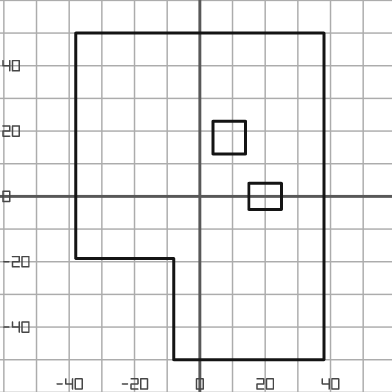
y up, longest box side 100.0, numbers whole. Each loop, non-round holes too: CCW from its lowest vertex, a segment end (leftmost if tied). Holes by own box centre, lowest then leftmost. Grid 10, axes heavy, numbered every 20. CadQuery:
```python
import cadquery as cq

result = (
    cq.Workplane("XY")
    .moveTo(-8.0, -50.0)
    .lineTo(38.0, -50.0)
    .lineTo(38.0, 50.0)
    .lineTo(-38.0, 50.0)
    .lineTo(-38.0, -19.0)
    .lineTo(-8.0, -19.0)
    .close()
    .moveTo(15.0, -4.0)
    .lineTo(25.0, -4.0)
    .lineTo(25.0, 4.0)
    .lineTo(15.0, 4.0)
    .close()
    .moveTo(4.0, 13.0)
    .lineTo(14.0, 13.0)
    .lineTo(14.0, 23.0)
    .lineTo(4.0, 23.0)
    .close()
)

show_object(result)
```